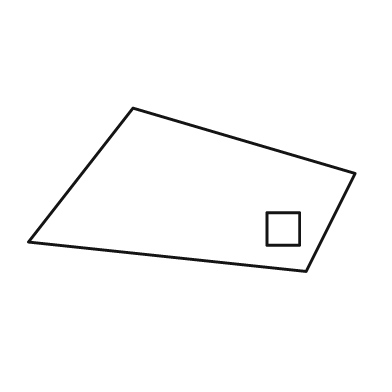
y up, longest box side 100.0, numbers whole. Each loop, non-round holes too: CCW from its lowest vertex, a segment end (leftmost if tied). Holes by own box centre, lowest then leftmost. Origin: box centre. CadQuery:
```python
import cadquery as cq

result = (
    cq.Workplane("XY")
    .moveTo(35.0, -25.0)
    .lineTo(50.0, 5.0)
    .lineTo(-18.0, 25.0)
    .lineTo(-50.0, -16.0)
    .close()
    .moveTo(23.0, -17.0)
    .lineTo(33.0, -17.0)
    .lineTo(33.0, -7.0)
    .lineTo(23.0, -7.0)
    .close()
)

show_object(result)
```